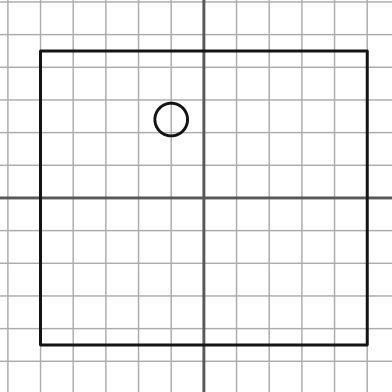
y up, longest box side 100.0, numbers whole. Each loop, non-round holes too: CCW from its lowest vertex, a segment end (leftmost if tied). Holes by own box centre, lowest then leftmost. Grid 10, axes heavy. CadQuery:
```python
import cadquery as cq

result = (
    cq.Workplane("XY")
    .moveTo(-50.0, -45.0)
    .lineTo(50.0, -45.0)
    .lineTo(50.0, 45.0)
    .lineTo(-50.0, 45.0)
    .close()
    .moveTo(-10.0, 24.0)
    .circle(5.0)
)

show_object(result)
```